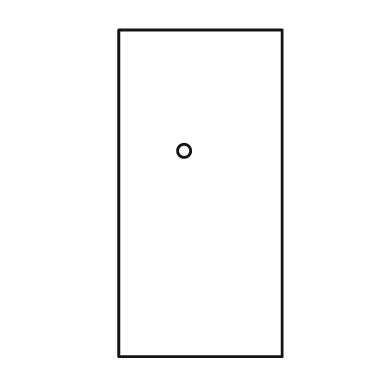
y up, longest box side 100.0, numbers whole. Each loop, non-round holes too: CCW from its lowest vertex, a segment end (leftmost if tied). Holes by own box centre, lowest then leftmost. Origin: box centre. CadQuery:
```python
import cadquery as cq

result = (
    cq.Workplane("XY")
    .moveTo(-25.0, -50.0)
    .lineTo(25.0, -50.0)
    .lineTo(25.0, 50.0)
    .lineTo(-25.0, 50.0)
    .close()
    .moveTo(-5.0, 13.0)
    .circle(2.0)
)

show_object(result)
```